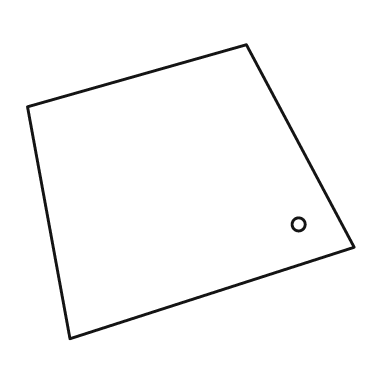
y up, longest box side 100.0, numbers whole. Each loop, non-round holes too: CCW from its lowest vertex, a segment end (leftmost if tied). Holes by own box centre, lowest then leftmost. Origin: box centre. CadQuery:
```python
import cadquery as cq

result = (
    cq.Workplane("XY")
    .moveTo(-37.0, -45.0)
    .lineTo(50.0, -17.0)
    .lineTo(17.0, 45.0)
    .lineTo(-50.0, 26.0)
    .close()
    .moveTo(33.0, -10.0)
    .circle(2.0)
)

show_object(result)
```